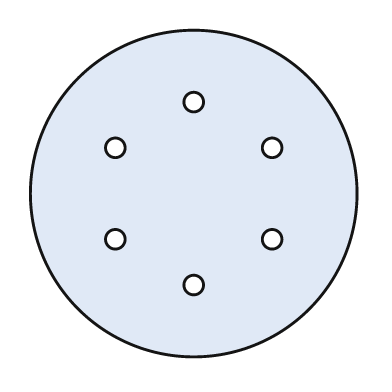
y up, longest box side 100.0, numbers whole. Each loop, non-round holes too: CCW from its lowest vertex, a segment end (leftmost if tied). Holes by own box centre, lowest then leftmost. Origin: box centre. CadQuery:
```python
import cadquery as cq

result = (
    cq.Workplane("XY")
    .moveTo(0.0, 0.0)
    .circle(50.0)
    .moveTo(0.0, -28.0)
    .circle(3.0)
    .moveTo(-24.0, -14.0)
    .circle(3.0)
    .moveTo(24.0, -14.0)
    .circle(3.0)
    .moveTo(-24.0, 14.0)
    .circle(3.0)
    .moveTo(24.0, 14.0)
    .circle(3.0)
    .moveTo(0.0, 28.0)
    .circle(3.0)
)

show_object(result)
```